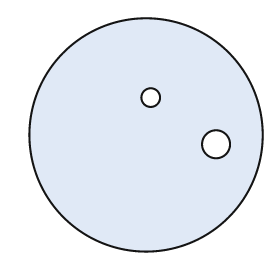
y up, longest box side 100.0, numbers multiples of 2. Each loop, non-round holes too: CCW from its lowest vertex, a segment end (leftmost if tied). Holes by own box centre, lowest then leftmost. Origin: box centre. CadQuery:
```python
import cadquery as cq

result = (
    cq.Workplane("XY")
    .moveTo(0.0, 0.0)
    .circle(50.0)
    .moveTo(30.0, -4.0)
    .circle(6.0)
    .moveTo(2.0, 16.0)
    .circle(4.0)
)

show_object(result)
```